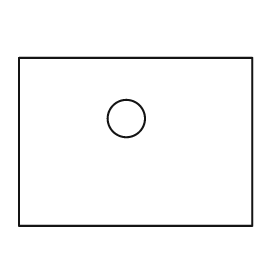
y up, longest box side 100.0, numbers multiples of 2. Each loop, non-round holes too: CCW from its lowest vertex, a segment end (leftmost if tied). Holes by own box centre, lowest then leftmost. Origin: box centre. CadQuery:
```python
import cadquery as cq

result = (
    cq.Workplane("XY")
    .moveTo(-50.0, -36.0)
    .lineTo(50.0, -36.0)
    .lineTo(50.0, 36.0)
    .lineTo(-50.0, 36.0)
    .close()
    .moveTo(-4.0, 10.0)
    .circle(8.0)
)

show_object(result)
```